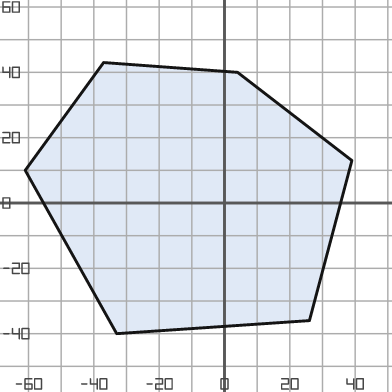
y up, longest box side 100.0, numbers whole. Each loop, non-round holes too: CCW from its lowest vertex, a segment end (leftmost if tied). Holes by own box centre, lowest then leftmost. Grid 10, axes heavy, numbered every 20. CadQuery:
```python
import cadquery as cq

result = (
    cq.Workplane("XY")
    .moveTo(-33.0, -40.0)
    .lineTo(26.0, -36.0)
    .lineTo(39.0, 13.0)
    .lineTo(4.0, 40.0)
    .lineTo(-37.0, 43.0)
    .lineTo(-61.0, 10.0)
    .close()
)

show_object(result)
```